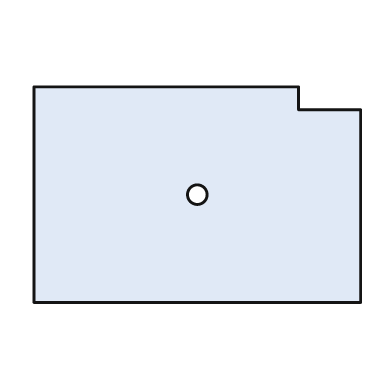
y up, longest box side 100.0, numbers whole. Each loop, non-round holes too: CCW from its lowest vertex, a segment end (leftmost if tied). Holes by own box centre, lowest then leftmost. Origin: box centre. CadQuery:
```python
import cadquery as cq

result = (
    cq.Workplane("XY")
    .moveTo(-50.0, -33.0)
    .lineTo(50.0, -33.0)
    .lineTo(50.0, 26.0)
    .lineTo(31.0, 26.0)
    .lineTo(31.0, 33.0)
    .lineTo(-50.0, 33.0)
    .close()
    .moveTo(0.0, 0.0)
    .circle(3.0)
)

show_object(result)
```